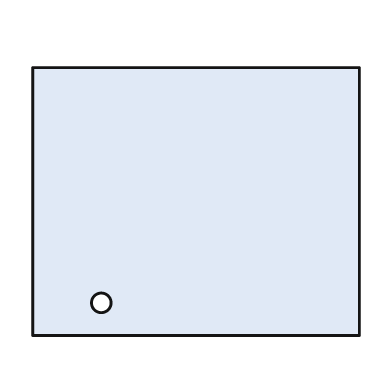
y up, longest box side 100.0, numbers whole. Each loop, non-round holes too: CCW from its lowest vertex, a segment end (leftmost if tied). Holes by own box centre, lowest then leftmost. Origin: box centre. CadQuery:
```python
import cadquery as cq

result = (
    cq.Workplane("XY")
    .moveTo(-50.0, -41.0)
    .lineTo(50.0, -41.0)
    .lineTo(50.0, 41.0)
    .lineTo(-50.0, 41.0)
    .close()
    .moveTo(-29.0, -31.0)
    .circle(3.0)
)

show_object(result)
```